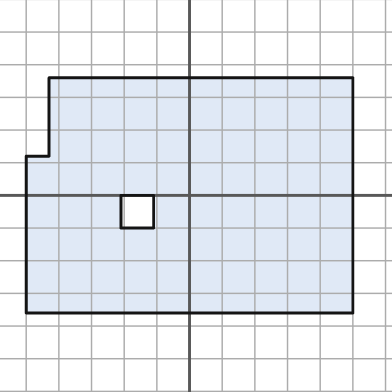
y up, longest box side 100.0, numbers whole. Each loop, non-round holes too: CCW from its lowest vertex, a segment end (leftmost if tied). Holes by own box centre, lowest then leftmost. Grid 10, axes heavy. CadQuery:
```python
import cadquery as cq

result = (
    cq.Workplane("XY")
    .moveTo(-50.0, -36.0)
    .lineTo(50.0, -36.0)
    .lineTo(50.0, 36.0)
    .lineTo(-43.0, 36.0)
    .lineTo(-43.0, 12.0)
    .lineTo(-50.0, 12.0)
    .close()
    .moveTo(-21.0, -10.0)
    .lineTo(-11.0, -10.0)
    .lineTo(-11.0, 0.0)
    .lineTo(-21.0, 0.0)
    .close()
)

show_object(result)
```